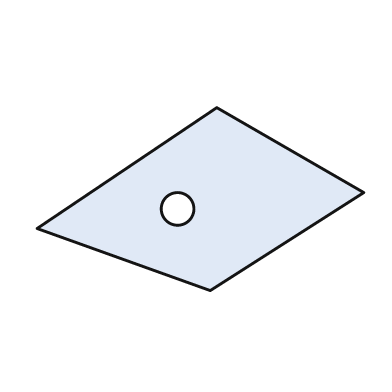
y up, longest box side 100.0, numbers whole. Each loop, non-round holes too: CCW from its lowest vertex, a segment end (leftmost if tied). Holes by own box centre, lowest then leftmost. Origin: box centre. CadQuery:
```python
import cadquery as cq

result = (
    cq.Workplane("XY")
    .moveTo(3.0, -28.0)
    .lineTo(50.0, 2.0)
    .lineTo(5.0, 28.0)
    .lineTo(-50.0, -9.0)
    .close()
    .moveTo(-7.0, -3.0)
    .circle(5.0)
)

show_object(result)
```